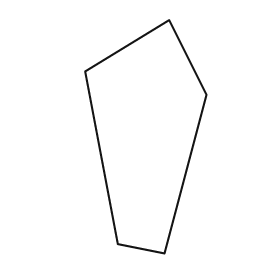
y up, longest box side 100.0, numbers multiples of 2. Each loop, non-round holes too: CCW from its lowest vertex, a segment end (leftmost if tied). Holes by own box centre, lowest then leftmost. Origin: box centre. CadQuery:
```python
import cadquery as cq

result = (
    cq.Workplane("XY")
    .moveTo(8.0, -50.0)
    .lineTo(26.0, 18.0)
    .lineTo(10.0, 50.0)
    .lineTo(-26.0, 28.0)
    .lineTo(-12.0, -46.0)
    .close()
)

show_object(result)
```